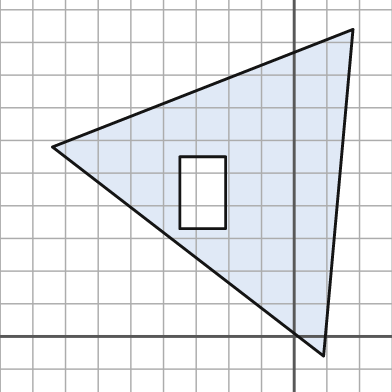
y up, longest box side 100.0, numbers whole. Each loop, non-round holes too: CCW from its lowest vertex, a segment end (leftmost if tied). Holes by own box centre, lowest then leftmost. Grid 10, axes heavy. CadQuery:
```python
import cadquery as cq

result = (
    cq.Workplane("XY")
    .moveTo(9.0, -6.0)
    .lineTo(18.0, 94.0)
    .lineTo(-74.0, 58.0)
    .close()
    .moveTo(-35.0, 33.0)
    .lineTo(-21.0, 33.0)
    .lineTo(-21.0, 55.0)
    .lineTo(-35.0, 55.0)
    .close()
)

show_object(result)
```